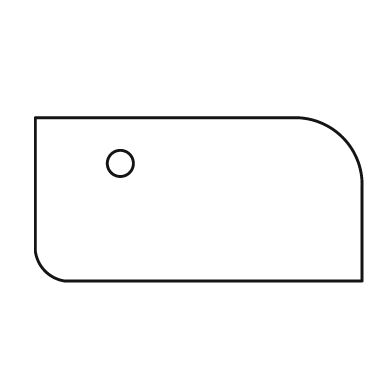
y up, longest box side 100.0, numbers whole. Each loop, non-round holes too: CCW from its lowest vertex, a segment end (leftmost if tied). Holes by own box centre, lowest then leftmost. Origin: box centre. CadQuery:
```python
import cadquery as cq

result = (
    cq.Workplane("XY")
    .moveTo(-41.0, -25.0)
    .lineTo(50.0, -25.0)
    .lineTo(50.0, 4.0)
    .threePointArc((44.0, 19.0), (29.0, 25.0))
    .lineTo(-50.0, 25.0)
    .lineTo(-50.0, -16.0)
    .threePointArc((-47.0, -22.0), (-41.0, -25.0))
    .close()
    .moveTo(-24.0, 11.0)
    .circle(4.0)
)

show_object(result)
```